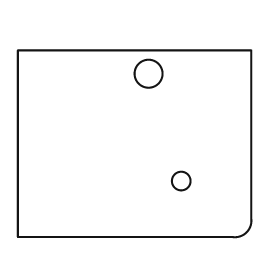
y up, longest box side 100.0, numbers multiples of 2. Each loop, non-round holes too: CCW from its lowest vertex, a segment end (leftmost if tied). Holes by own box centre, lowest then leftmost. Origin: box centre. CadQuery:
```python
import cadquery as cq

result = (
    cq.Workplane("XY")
    .moveTo(-50.0, -40.0)
    .lineTo(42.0, -40.0)
    .threePointArc((48.0, -38.0), (50.0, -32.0))
    .lineTo(50.0, 40.0)
    .lineTo(-50.0, 40.0)
    .close()
    .moveTo(20.0, -16.0)
    .circle(4.0)
    .moveTo(6.0, 30.0)
    .circle(6.0)
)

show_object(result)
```